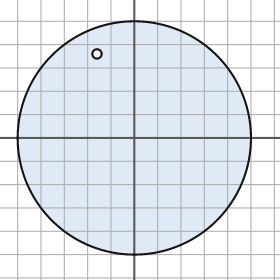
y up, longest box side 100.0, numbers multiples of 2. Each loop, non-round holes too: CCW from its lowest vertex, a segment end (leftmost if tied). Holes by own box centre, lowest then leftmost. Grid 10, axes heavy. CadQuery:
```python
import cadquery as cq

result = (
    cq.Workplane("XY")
    .moveTo(0.0, 0.0)
    .circle(50.0)
    .moveTo(-16.0, 36.0)
    .circle(2.0)
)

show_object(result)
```